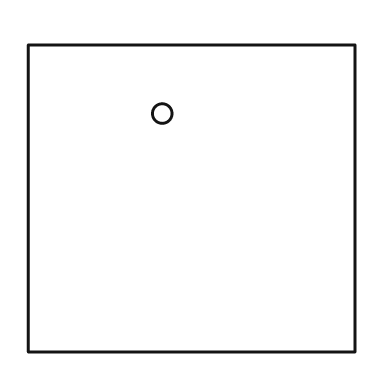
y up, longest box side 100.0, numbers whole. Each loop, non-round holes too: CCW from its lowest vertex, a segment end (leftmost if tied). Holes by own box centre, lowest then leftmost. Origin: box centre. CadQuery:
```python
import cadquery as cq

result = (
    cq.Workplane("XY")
    .moveTo(-50.0, -47.0)
    .lineTo(50.0, -47.0)
    .lineTo(50.0, 47.0)
    .lineTo(-50.0, 47.0)
    .close()
    .moveTo(-9.0, 26.0)
    .circle(3.0)
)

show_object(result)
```